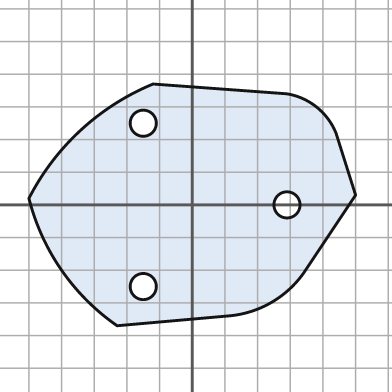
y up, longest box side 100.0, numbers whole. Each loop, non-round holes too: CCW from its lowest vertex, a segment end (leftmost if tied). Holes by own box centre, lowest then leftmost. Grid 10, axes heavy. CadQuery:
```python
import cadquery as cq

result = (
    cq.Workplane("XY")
    .moveTo(-23.0, -37.0)
    .lineTo(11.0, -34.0)
    .threePointArc((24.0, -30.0), (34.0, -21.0))
    .lineTo(50.0, 3.0)
    .lineTo(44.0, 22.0)
    .threePointArc((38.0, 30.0), (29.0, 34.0))
    .lineTo(-12.0, 37.0)
    .threePointArc((-34.0, 23.0), (-50.0, 2.0))
    .threePointArc((-40.0, -20.0), (-23.0, -37.0))
    .close()
    .moveTo(-15.0, -25.0)
    .circle(4.0)
    .moveTo(29.0, 0.0)
    .circle(4.0)
    .moveTo(-15.0, 25.0)
    .circle(4.0)
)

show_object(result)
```